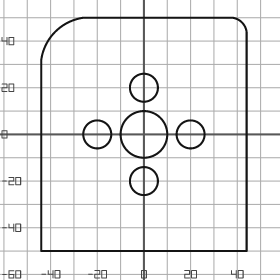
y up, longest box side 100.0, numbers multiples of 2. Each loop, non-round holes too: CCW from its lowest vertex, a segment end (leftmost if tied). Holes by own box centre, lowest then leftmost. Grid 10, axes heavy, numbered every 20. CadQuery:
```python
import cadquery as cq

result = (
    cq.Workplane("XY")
    .moveTo(-44.0, -50.0)
    .lineTo(44.0, -50.0)
    .lineTo(44.0, 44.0)
    .threePointArc((42.0, 48.0), (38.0, 50.0))
    .lineTo(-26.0, 50.0)
    .threePointArc((-38.0, 44.0), (-44.0, 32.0))
    .close()
    .moveTo(0.0, -20.0)
    .circle(6.0)
    .moveTo(-20.0, 0.0)
    .circle(6.0)
    .moveTo(0.0, 0.0)
    .circle(10.0)
    .moveTo(20.0, 0.0)
    .circle(6.0)
    .moveTo(0.0, 20.0)
    .circle(6.0)
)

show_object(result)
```